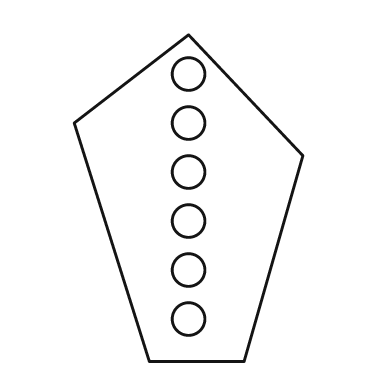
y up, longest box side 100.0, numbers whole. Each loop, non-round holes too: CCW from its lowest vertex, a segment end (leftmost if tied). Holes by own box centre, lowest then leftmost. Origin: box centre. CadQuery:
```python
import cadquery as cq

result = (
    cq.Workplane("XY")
    .moveTo(-12.0, -50.0)
    .lineTo(17.0, -50.0)
    .lineTo(35.0, 13.0)
    .lineTo(0.0, 50.0)
    .lineTo(-35.0, 23.0)
    .close()
    .moveTo(0.0, -37.0)
    .circle(5.0)
    .moveTo(0.0, -22.0)
    .circle(5.0)
    .moveTo(0.0, -7.0)
    .circle(5.0)
    .moveTo(0.0, 8.0)
    .circle(5.0)
    .moveTo(0.0, 23.0)
    .circle(5.0)
    .moveTo(0.0, 38.0)
    .circle(5.0)
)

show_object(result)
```